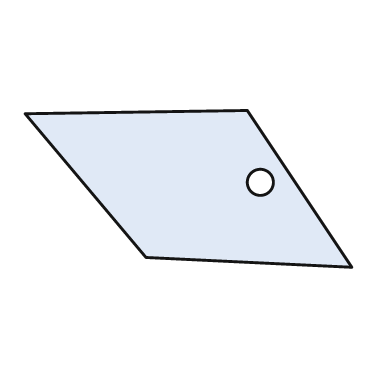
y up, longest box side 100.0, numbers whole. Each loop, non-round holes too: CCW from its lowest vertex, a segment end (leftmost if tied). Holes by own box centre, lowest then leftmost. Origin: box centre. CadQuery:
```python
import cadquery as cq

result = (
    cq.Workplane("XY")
    .moveTo(50.0, -24.0)
    .lineTo(18.0, 24.0)
    .lineTo(-50.0, 23.0)
    .lineTo(-13.0, -21.0)
    .close()
    .moveTo(22.0, 2.0)
    .circle(4.0)
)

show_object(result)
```